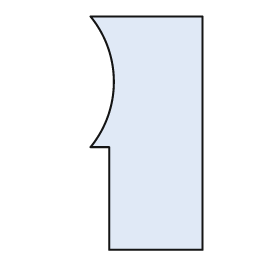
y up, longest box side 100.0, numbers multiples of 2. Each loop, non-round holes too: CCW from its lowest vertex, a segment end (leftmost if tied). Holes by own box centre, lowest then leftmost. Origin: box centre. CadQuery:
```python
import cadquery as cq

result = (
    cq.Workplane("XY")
    .moveTo(-16.0, -50.0)
    .lineTo(24.0, -50.0)
    .lineTo(24.0, 50.0)
    .lineTo(-24.0, 50.0)
    .threePointArc((-14.0, 22.0), (-24.0, -6.0))
    .lineTo(-16.0, -6.0)
    .close()
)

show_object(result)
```